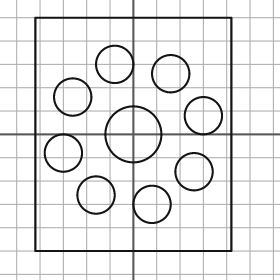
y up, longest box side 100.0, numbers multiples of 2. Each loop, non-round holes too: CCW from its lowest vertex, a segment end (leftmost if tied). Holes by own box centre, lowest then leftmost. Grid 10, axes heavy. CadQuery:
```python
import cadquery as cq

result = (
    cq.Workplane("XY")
    .moveTo(-42.0, -50.0)
    .lineTo(42.0, -50.0)
    .lineTo(42.0, 50.0)
    .lineTo(-42.0, 50.0)
    .close()
    .moveTo(8.0, -30.0)
    .circle(8.0)
    .moveTo(-16.0, -26.0)
    .circle(8.0)
    .moveTo(26.0, -16.0)
    .circle(8.0)
    .moveTo(-30.0, -8.0)
    .circle(8.0)
    .moveTo(0.0, 0.0)
    .circle(12.0)
    .moveTo(30.0, 8.0)
    .circle(8.0)
    .moveTo(-26.0, 16.0)
    .circle(8.0)
    .moveTo(16.0, 26.0)
    .circle(8.0)
    .moveTo(-8.0, 30.0)
    .circle(8.0)
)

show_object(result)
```